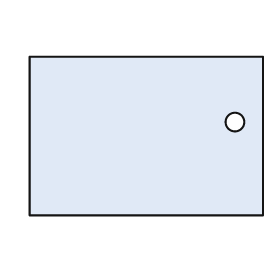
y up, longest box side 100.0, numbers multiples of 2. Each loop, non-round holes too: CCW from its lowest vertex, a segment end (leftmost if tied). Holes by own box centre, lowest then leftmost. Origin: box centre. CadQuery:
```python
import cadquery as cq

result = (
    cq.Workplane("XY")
    .moveTo(-50.0, -34.0)
    .lineTo(50.0, -34.0)
    .lineTo(50.0, 34.0)
    .lineTo(-50.0, 34.0)
    .close()
    .moveTo(38.0, 6.0)
    .circle(4.0)
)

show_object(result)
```